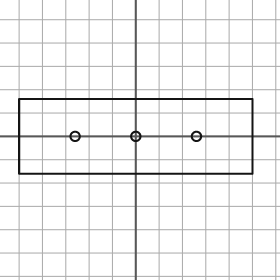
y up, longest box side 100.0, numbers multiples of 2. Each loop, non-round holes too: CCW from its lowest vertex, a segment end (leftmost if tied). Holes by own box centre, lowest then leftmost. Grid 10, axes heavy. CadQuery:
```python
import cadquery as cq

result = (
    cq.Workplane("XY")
    .moveTo(-50.0, -16.0)
    .lineTo(50.0, -16.0)
    .lineTo(50.0, 16.0)
    .lineTo(-50.0, 16.0)
    .close()
    .moveTo(-26.0, 0.0)
    .circle(2.0)
    .moveTo(0.0, 0.0)
    .circle(2.0)
    .moveTo(26.0, 0.0)
    .circle(2.0)
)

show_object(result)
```